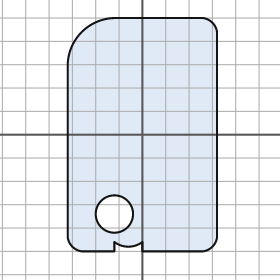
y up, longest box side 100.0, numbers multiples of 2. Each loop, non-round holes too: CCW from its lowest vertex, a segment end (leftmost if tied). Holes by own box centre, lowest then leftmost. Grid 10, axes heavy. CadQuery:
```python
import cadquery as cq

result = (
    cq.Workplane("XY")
    .moveTo(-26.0, -50.0)
    .lineTo(-12.0, -50.0)
    .lineTo(-12.0, -46.0)
    .threePointArc((-6.0, -48.0), (0.0, -46.0))
    .lineTo(0.0, -50.0)
    .lineTo(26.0, -50.0)
    .threePointArc((30.0, -48.0), (32.0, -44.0))
    .lineTo(32.0, 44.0)
    .threePointArc((30.0, 48.0), (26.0, 50.0))
    .lineTo(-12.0, 50.0)
    .threePointArc((-26.0, 44.0), (-32.0, 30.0))
    .lineTo(-32.0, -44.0)
    .threePointArc((-30.0, -48.0), (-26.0, -50.0))
    .close()
    .moveTo(-12.0, -34.0)
    .circle(8.0)
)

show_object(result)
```